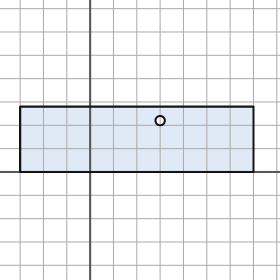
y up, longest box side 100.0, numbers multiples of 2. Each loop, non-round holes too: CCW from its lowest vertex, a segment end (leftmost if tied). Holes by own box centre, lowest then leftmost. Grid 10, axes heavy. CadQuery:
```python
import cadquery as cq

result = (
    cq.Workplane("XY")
    .moveTo(-30.0, 0.0)
    .lineTo(70.0, 0.0)
    .lineTo(70.0, 28.0)
    .lineTo(-30.0, 28.0)
    .close()
    .moveTo(30.0, 22.0)
    .circle(2.0)
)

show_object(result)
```